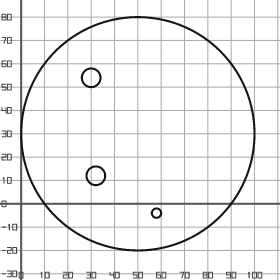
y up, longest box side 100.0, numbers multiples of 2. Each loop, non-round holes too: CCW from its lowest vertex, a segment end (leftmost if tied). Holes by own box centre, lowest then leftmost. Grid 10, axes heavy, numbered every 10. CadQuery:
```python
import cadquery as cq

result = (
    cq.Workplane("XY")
    .moveTo(50.0, 30.0)
    .circle(50.0)
    .moveTo(58.0, -4.0)
    .circle(2.0)
    .moveTo(32.0, 12.0)
    .circle(4.0)
    .moveTo(30.0, 54.0)
    .circle(4.0)
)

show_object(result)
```